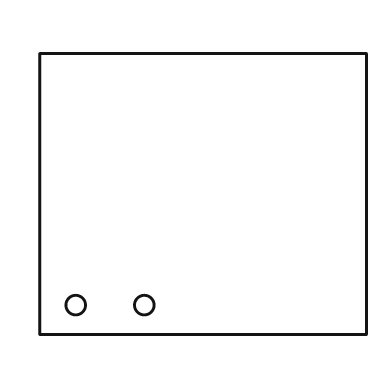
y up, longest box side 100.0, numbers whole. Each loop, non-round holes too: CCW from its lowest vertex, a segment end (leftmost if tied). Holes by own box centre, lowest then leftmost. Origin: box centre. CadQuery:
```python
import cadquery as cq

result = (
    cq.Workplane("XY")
    .moveTo(-50.0, -43.0)
    .lineTo(50.0, -43.0)
    .lineTo(50.0, 43.0)
    .lineTo(-50.0, 43.0)
    .close()
    .moveTo(-39.0, -34.0)
    .circle(3.0)
    .moveTo(-18.0, -34.0)
    .circle(3.0)
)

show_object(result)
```